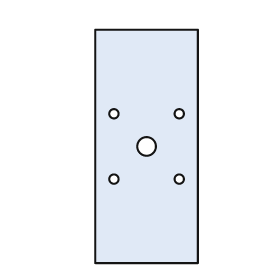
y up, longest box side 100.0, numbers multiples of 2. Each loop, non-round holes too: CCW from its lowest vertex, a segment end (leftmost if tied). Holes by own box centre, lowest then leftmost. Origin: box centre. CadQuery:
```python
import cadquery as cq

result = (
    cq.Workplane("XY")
    .moveTo(-22.0, -50.0)
    .lineTo(22.0, -50.0)
    .lineTo(22.0, 50.0)
    .lineTo(-22.0, 50.0)
    .close()
    .moveTo(-14.0, -14.0)
    .circle(2.0)
    .moveTo(14.0, -14.0)
    .circle(2.0)
    .moveTo(0.0, 0.0)
    .circle(4.0)
    .moveTo(-14.0, 14.0)
    .circle(2.0)
    .moveTo(14.0, 14.0)
    .circle(2.0)
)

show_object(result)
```